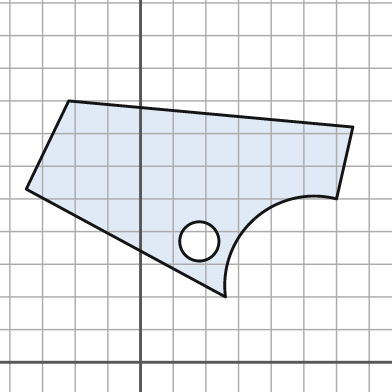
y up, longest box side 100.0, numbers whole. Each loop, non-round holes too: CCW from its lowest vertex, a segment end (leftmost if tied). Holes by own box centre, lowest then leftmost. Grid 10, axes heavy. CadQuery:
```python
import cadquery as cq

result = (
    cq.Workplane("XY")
    .moveTo(26.0, 20.0)
    .threePointArc((35.0, 44.0), (60.0, 50.0))
    .lineTo(65.0, 72.0)
    .lineTo(-22.0, 80.0)
    .lineTo(-35.0, 53.0)
    .close()
    .moveTo(18.0, 37.0)
    .circle(6.0)
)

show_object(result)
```